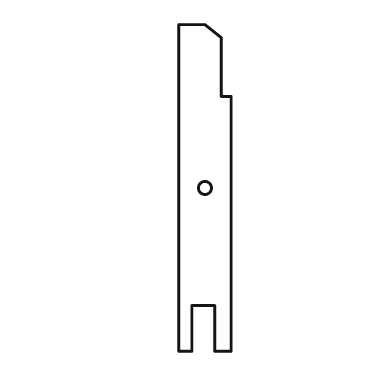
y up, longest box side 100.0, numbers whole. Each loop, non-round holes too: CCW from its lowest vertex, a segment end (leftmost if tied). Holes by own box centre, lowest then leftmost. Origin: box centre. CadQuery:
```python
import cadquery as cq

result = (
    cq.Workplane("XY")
    .moveTo(-8.0, -50.0)
    .lineTo(-4.0, -50.0)
    .lineTo(-4.0, -36.0)
    .lineTo(3.0, -36.0)
    .lineTo(3.0, -50.0)
    .lineTo(8.0, -50.0)
    .lineTo(8.0, 28.0)
    .lineTo(5.0, 28.0)
    .lineTo(5.0, 46.0)
    .lineTo(0.0, 50.0)
    .lineTo(-8.0, 50.0)
    .close()
    .moveTo(0.0, 0.0)
    .circle(2.0)
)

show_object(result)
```